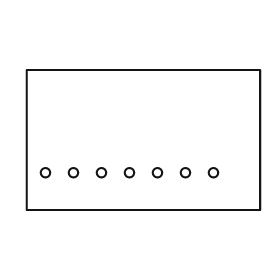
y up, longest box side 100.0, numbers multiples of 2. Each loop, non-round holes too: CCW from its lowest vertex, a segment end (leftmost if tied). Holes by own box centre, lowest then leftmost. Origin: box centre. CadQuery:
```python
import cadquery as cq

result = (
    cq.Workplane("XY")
    .moveTo(-50.0, -30.0)
    .lineTo(50.0, -30.0)
    .lineTo(50.0, 30.0)
    .lineTo(-50.0, 30.0)
    .close()
    .moveTo(-42.0, -14.0)
    .circle(2.0)
    .moveTo(-30.0, -14.0)
    .circle(2.0)
    .moveTo(-18.0, -14.0)
    .circle(2.0)
    .moveTo(-6.0, -14.0)
    .circle(2.0)
    .moveTo(6.0, -14.0)
    .circle(2.0)
    .moveTo(18.0, -14.0)
    .circle(2.0)
    .moveTo(30.0, -14.0)
    .circle(2.0)
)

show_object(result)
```